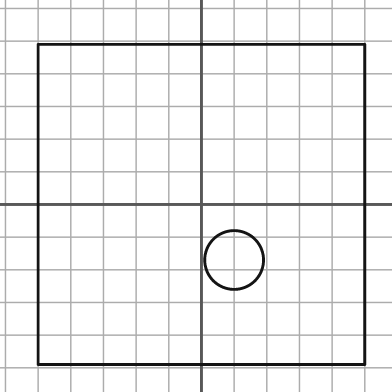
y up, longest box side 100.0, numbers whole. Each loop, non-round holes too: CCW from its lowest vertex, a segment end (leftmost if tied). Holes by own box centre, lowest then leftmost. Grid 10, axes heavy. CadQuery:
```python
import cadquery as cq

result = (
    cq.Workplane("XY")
    .moveTo(-50.0, -49.0)
    .lineTo(50.0, -49.0)
    .lineTo(50.0, 49.0)
    .lineTo(-50.0, 49.0)
    .close()
    .moveTo(10.0, -17.0)
    .circle(9.0)
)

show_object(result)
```